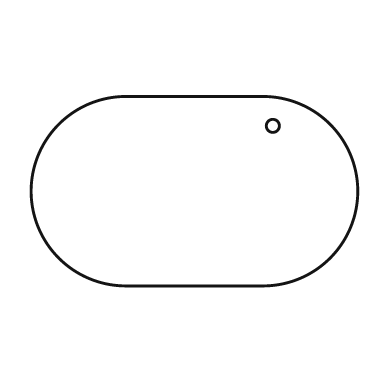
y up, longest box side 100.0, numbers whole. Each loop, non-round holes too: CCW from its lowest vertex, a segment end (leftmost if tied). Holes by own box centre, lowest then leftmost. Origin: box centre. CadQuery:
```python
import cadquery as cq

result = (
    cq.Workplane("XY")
    .moveTo(-21.0, -29.0)
    .lineTo(21.0, -29.0)
    .threePointArc((50.0, 0.0), (21.0, 29.0))
    .lineTo(-21.0, 29.0)
    .threePointArc((-50.0, 0.0), (-21.0, -29.0))
    .close()
    .moveTo(24.0, 20.0)
    .circle(2.0)
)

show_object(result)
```